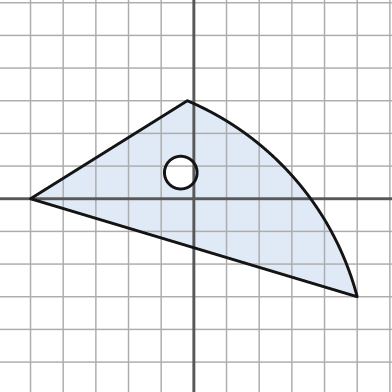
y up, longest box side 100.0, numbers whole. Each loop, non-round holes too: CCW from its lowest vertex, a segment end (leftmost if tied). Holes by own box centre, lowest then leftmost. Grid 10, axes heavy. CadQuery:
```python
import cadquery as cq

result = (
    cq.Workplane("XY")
    .moveTo(50.0, -30.0)
    .threePointArc((31.0, 6.0), (-2.0, 30.0))
    .lineTo(-50.0, 0.0)
    .close()
    .moveTo(-4.0, 8.0)
    .circle(5.0)
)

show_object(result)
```